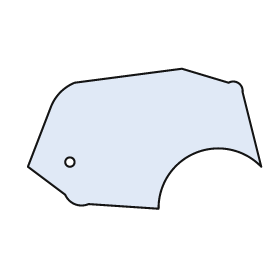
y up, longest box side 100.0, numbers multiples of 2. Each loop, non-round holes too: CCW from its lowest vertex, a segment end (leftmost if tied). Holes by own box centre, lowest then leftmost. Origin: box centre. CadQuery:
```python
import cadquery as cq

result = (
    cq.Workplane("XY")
    .moveTo(6.0, -30.0)
    .threePointArc((22.0, -6.0), (50.0, -12.0))
    .lineTo(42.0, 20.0)
    .threePointArc((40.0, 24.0), (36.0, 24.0))
    .lineTo(16.0, 30.0)
    .lineTo(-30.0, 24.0)
    .threePointArc((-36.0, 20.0), (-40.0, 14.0))
    .lineTo(-50.0, -12.0)
    .lineTo(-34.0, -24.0)
    .threePointArc((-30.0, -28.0), (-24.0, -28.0))
    .close()
    .moveTo(-32.0, -10.0)
    .circle(2.0)
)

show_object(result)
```